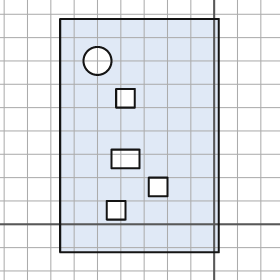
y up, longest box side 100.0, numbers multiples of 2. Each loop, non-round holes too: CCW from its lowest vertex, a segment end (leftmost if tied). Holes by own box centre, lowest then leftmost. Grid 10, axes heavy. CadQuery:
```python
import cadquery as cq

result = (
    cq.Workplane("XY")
    .moveTo(-66.0, -12.0)
    .lineTo(2.0, -12.0)
    .lineTo(2.0, 88.0)
    .lineTo(-66.0, 88.0)
    .close()
    .moveTo(-46.0, 2.0)
    .lineTo(-38.0, 2.0)
    .lineTo(-38.0, 10.0)
    .lineTo(-46.0, 10.0)
    .close()
    .moveTo(-28.0, 12.0)
    .lineTo(-20.0, 12.0)
    .lineTo(-20.0, 20.0)
    .lineTo(-28.0, 20.0)
    .close()
    .moveTo(-44.0, 24.0)
    .lineTo(-32.0, 24.0)
    .lineTo(-32.0, 32.0)
    .lineTo(-44.0, 32.0)
    .close()
    .moveTo(-42.0, 50.0)
    .lineTo(-34.0, 50.0)
    .lineTo(-34.0, 58.0)
    .lineTo(-42.0, 58.0)
    .close()
    .moveTo(-50.0, 70.0)
    .circle(6.0)
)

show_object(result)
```